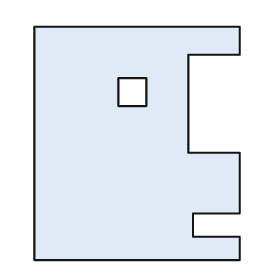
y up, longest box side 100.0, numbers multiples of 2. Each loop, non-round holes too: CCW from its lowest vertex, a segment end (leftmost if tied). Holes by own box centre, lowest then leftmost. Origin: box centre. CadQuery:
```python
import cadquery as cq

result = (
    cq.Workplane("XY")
    .moveTo(-44.0, -50.0)
    .lineTo(44.0, -50.0)
    .lineTo(44.0, -40.0)
    .lineTo(24.0, -40.0)
    .lineTo(24.0, -30.0)
    .lineTo(44.0, -30.0)
    .lineTo(44.0, -4.0)
    .lineTo(22.0, -4.0)
    .lineTo(22.0, 38.0)
    .lineTo(44.0, 38.0)
    .lineTo(44.0, 50.0)
    .lineTo(-44.0, 50.0)
    .close()
    .moveTo(-8.0, 16.0)
    .lineTo(4.0, 16.0)
    .lineTo(4.0, 28.0)
    .lineTo(-8.0, 28.0)
    .close()
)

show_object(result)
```